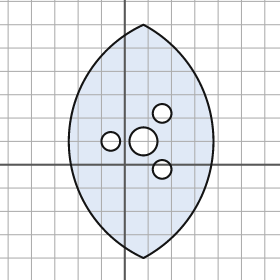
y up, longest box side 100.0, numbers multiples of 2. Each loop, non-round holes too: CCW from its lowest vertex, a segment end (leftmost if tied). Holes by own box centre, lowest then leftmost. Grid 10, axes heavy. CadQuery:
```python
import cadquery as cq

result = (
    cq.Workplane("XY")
    .moveTo(8.0, -40.0)
    .threePointArc((38.0, 10.0), (8.0, 60.0))
    .threePointArc((-24.0, 10.0), (8.0, -40.0))
    .close()
    .moveTo(16.0, -2.0)
    .circle(4.0)
    .moveTo(-6.0, 10.0)
    .circle(4.0)
    .moveTo(8.0, 10.0)
    .circle(6.0)
    .moveTo(16.0, 22.0)
    .circle(4.0)
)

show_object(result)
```